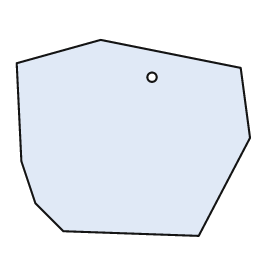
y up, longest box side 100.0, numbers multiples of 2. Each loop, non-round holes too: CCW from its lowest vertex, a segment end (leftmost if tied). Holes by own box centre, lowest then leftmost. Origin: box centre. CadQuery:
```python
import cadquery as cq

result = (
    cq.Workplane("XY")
    .moveTo(28.0, -42.0)
    .lineTo(50.0, 0.0)
    .lineTo(46.0, 30.0)
    .lineTo(-14.0, 42.0)
    .lineTo(-50.0, 32.0)
    .lineTo(-48.0, -10.0)
    .lineTo(-42.0, -28.0)
    .lineTo(-30.0, -40.0)
    .close()
    .moveTo(8.0, 26.0)
    .circle(2.0)
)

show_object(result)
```